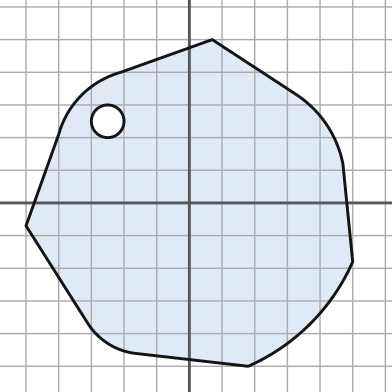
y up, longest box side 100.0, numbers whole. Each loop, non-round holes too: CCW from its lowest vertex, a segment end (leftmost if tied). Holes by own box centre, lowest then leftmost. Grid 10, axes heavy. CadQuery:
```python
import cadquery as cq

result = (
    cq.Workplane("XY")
    .moveTo(18.0, -50.0)
    .threePointArc((37.0, -37.0), (50.0, -18.0))
    .lineTo(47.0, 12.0)
    .threePointArc((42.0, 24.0), (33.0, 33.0))
    .lineTo(7.0, 50.0)
    .lineTo(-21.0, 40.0)
    .threePointArc((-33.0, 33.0), (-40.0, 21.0))
    .lineTo(-50.0, -7.0)
    .lineTo(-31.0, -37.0)
    .threePointArc((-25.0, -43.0), (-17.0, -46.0))
    .close()
    .moveTo(-25.0, 25.0)
    .circle(5.0)
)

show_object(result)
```